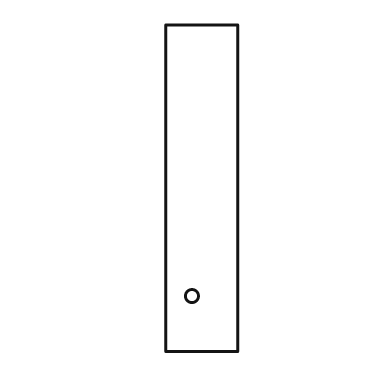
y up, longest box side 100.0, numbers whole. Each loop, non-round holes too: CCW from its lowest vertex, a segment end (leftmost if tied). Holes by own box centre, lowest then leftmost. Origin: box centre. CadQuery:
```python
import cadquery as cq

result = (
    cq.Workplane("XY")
    .moveTo(-11.0, -50.0)
    .lineTo(11.0, -50.0)
    .lineTo(11.0, 50.0)
    .lineTo(-11.0, 50.0)
    .close()
    .moveTo(-3.0, -33.0)
    .circle(2.0)
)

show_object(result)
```